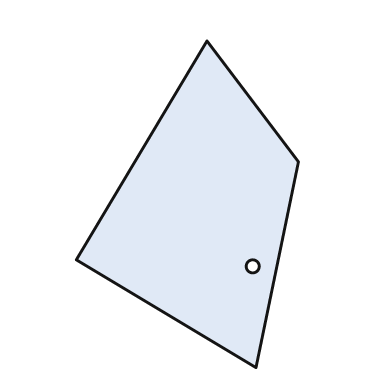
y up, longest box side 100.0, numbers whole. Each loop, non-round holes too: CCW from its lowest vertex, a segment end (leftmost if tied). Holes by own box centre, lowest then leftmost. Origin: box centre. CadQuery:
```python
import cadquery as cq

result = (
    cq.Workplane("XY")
    .moveTo(21.0, -50.0)
    .lineTo(34.0, 13.0)
    .lineTo(6.0, 50.0)
    .lineTo(-34.0, -17.0)
    .close()
    .moveTo(20.0, -19.0)
    .circle(2.0)
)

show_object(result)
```